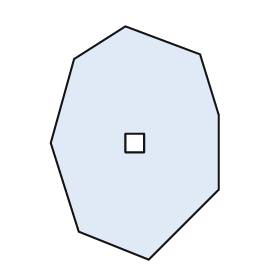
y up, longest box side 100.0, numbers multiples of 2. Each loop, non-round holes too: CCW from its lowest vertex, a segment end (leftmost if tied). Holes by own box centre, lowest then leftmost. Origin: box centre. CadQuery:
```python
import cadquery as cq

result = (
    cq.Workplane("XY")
    .moveTo(6.0, -50.0)
    .lineTo(36.0, -20.0)
    .lineTo(36.0, 12.0)
    .lineTo(28.0, 38.0)
    .lineTo(-4.0, 50.0)
    .lineTo(-26.0, 36.0)
    .lineTo(-36.0, 0.0)
    .lineTo(-24.0, -38.0)
    .close()
    .moveTo(-4.0, -4.0)
    .lineTo(4.0, -4.0)
    .lineTo(4.0, 4.0)
    .lineTo(-4.0, 4.0)
    .close()
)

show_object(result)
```